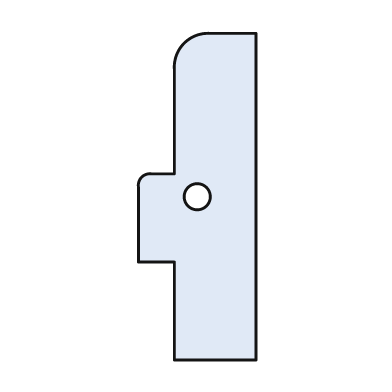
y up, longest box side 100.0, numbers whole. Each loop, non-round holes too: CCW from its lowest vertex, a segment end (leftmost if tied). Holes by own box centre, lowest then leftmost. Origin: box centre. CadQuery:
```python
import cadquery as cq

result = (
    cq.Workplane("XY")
    .moveTo(-7.0, -50.0)
    .lineTo(18.0, -50.0)
    .lineTo(18.0, 50.0)
    .lineTo(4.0, 50.0)
    .threePointArc((-4.0, 47.0), (-7.0, 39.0))
    .lineTo(-7.0, 7.0)
    .lineTo(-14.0, 7.0)
    .threePointArc((-17.0, 6.0), (-18.0, 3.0))
    .lineTo(-18.0, -20.0)
    .lineTo(-7.0, -20.0)
    .close()
    .moveTo(0.0, 0.0)
    .circle(4.0)
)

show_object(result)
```